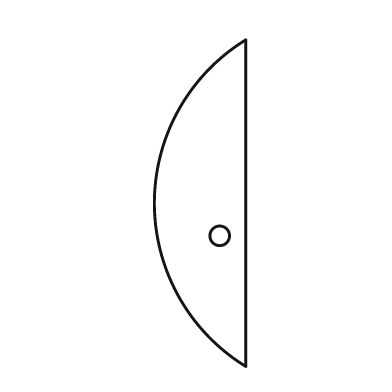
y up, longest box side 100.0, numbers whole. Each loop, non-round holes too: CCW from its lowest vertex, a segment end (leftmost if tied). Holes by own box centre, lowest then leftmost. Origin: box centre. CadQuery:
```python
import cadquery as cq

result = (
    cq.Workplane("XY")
    .moveTo(14.0, -50.0)
    .lineTo(14.0, 50.0)
    .threePointArc((-14.0, 0.0), (14.0, -50.0))
    .close()
    .moveTo(6.0, -10.0)
    .circle(3.0)
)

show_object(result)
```